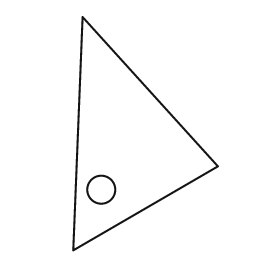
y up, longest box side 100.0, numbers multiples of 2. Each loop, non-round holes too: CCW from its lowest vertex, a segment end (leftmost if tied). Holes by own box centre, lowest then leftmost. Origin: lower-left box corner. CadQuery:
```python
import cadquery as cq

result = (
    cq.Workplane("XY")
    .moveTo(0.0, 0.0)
    .lineTo(62.0, 36.0)
    .lineTo(4.0, 100.0)
    .close()
    .moveTo(12.0, 26.0)
    .circle(6.0)
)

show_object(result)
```